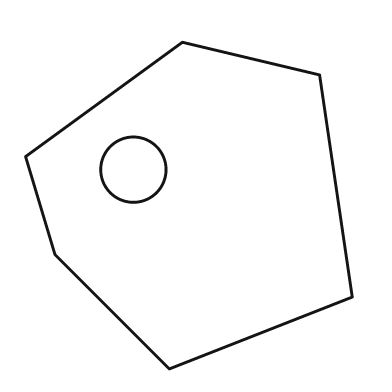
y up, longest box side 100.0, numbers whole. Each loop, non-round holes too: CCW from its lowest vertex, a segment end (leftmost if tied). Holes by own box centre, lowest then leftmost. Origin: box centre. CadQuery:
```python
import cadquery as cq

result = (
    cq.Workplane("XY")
    .moveTo(-6.0, -50.0)
    .lineTo(50.0, -28.0)
    .lineTo(40.0, 40.0)
    .lineTo(-2.0, 50.0)
    .lineTo(-50.0, 15.0)
    .lineTo(-41.0, -15.0)
    .close()
    .moveTo(-17.0, 11.0)
    .circle(10.0)
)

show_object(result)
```